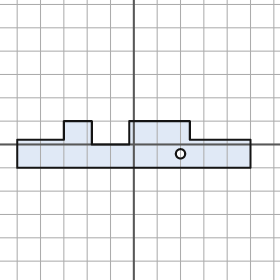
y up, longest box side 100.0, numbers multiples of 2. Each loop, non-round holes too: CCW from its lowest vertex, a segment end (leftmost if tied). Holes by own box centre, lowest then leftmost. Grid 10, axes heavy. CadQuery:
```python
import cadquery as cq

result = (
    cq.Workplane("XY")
    .moveTo(-50.0, -10.0)
    .lineTo(50.0, -10.0)
    .lineTo(50.0, 2.0)
    .lineTo(24.0, 2.0)
    .lineTo(24.0, 10.0)
    .lineTo(-2.0, 10.0)
    .lineTo(-2.0, 0.0)
    .lineTo(-18.0, 0.0)
    .lineTo(-18.0, 10.0)
    .lineTo(-30.0, 10.0)
    .lineTo(-30.0, 2.0)
    .lineTo(-50.0, 2.0)
    .close()
    .moveTo(20.0, -4.0)
    .circle(2.0)
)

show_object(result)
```